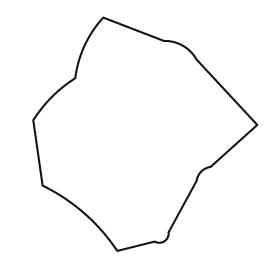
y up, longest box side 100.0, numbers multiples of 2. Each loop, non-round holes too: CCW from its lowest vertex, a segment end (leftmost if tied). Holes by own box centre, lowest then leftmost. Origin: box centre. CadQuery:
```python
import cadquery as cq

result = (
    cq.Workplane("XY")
    .moveTo(-12.0, -50.0)
    .lineTo(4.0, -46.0)
    .threePointArc((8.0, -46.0), (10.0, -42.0))
    .lineTo(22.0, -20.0)
    .threePointArc((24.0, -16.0), (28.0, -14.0))
    .lineTo(48.0, 4.0)
    .lineTo(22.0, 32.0)
    .threePointArc((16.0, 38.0), (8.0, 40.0))
    .lineTo(-18.0, 50.0)
    .threePointArc((-26.0, 38.0), (-30.0, 24.0))
    .threePointArc((-40.0, 16.0), (-48.0, 6.0))
    .lineTo(-44.0, -22.0)
    .threePointArc((-26.0, -34.0), (-12.0, -50.0))
    .close()
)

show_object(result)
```